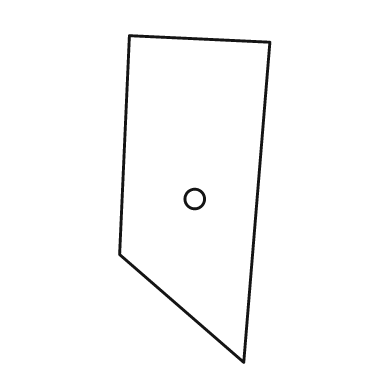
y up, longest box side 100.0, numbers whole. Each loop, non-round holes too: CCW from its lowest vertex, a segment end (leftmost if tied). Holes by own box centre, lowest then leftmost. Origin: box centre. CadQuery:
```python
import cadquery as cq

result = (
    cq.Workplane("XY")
    .moveTo(15.0, -50.0)
    .lineTo(23.0, 48.0)
    .lineTo(-20.0, 50.0)
    .lineTo(-23.0, -17.0)
    .close()
    .moveTo(0.0, 0.0)
    .circle(3.0)
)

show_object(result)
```